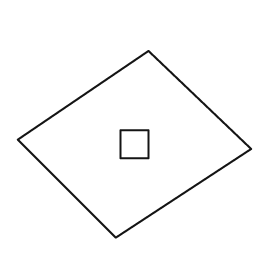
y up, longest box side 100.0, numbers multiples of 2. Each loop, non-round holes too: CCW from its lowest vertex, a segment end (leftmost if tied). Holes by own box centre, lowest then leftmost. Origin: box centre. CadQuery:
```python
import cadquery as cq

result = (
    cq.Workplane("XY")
    .moveTo(-8.0, -40.0)
    .lineTo(50.0, -2.0)
    .lineTo(6.0, 40.0)
    .lineTo(-50.0, 2.0)
    .close()
    .moveTo(-6.0, -6.0)
    .lineTo(6.0, -6.0)
    .lineTo(6.0, 6.0)
    .lineTo(-6.0, 6.0)
    .close()
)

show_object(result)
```